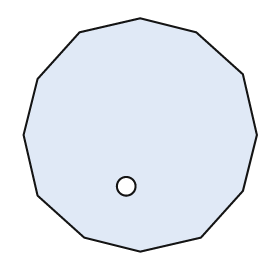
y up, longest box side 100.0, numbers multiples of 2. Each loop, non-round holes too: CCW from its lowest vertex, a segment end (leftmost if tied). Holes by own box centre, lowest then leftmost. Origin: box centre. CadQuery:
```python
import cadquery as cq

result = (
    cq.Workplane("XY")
    .moveTo(0.0, -50.0)
    .lineTo(26.0, -44.0)
    .lineTo(44.0, -24.0)
    .lineTo(50.0, 0.0)
    .lineTo(44.0, 26.0)
    .lineTo(24.0, 44.0)
    .lineTo(0.0, 50.0)
    .lineTo(-26.0, 44.0)
    .lineTo(-44.0, 24.0)
    .lineTo(-50.0, 0.0)
    .lineTo(-44.0, -26.0)
    .lineTo(-24.0, -44.0)
    .close()
    .moveTo(-6.0, -22.0)
    .circle(4.0)
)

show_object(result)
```